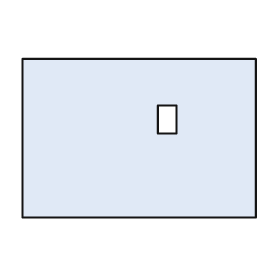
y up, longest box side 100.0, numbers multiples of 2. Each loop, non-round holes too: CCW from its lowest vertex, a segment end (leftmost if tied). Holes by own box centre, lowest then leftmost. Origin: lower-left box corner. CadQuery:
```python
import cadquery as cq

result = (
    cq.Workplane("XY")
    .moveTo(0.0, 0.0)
    .lineTo(100.0, 0.0)
    .lineTo(100.0, 68.0)
    .lineTo(0.0, 68.0)
    .close()
    .moveTo(58.0, 36.0)
    .lineTo(66.0, 36.0)
    .lineTo(66.0, 48.0)
    .lineTo(58.0, 48.0)
    .close()
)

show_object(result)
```